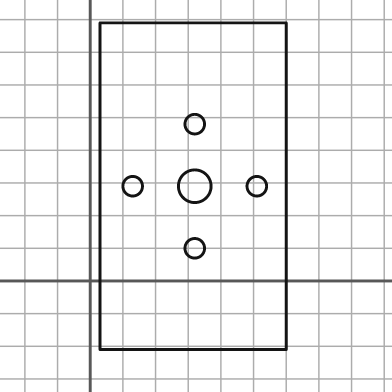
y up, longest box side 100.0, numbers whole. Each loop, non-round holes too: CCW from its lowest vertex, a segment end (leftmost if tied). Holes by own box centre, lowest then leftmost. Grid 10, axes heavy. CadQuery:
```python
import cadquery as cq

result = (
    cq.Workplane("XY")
    .moveTo(3.0, -21.0)
    .lineTo(60.0, -21.0)
    .lineTo(60.0, 79.0)
    .lineTo(3.0, 79.0)
    .close()
    .moveTo(32.0, 10.0)
    .circle(3.0)
    .moveTo(13.0, 29.0)
    .circle(3.0)
    .moveTo(32.0, 29.0)
    .circle(5.0)
    .moveTo(51.0, 29.0)
    .circle(3.0)
    .moveTo(32.0, 48.0)
    .circle(3.0)
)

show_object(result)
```